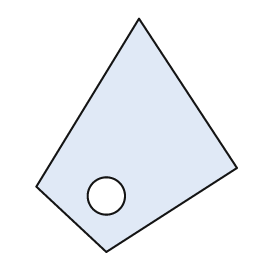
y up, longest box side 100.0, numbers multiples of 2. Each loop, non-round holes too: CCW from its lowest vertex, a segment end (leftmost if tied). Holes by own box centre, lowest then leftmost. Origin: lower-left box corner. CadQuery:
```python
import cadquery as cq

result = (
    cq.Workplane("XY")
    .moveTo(30.0, 0.0)
    .lineTo(86.0, 36.0)
    .lineTo(44.0, 100.0)
    .lineTo(0.0, 28.0)
    .close()
    .moveTo(30.0, 24.0)
    .circle(8.0)
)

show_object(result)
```